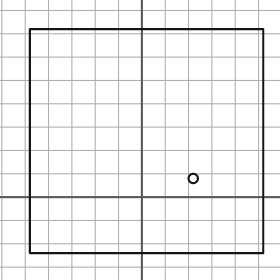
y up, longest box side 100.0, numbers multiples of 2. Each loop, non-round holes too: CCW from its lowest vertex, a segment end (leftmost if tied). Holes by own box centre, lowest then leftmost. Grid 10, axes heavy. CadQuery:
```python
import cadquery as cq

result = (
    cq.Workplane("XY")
    .moveTo(-48.0, -24.0)
    .lineTo(52.0, -24.0)
    .lineTo(52.0, 72.0)
    .lineTo(-48.0, 72.0)
    .close()
    .moveTo(22.0, 8.0)
    .circle(2.0)
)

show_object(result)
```